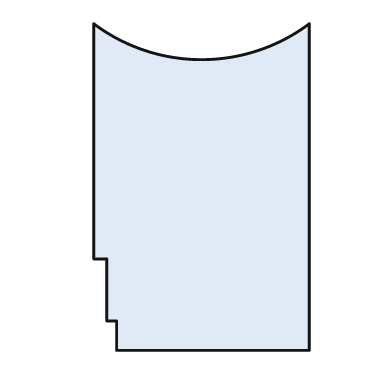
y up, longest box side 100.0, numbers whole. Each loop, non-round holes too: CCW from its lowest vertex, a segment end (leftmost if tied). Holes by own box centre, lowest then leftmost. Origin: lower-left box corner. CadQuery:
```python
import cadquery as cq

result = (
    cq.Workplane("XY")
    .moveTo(7.0, 0.0)
    .lineTo(66.0, 0.0)
    .lineTo(66.0, 100.0)
    .threePointArc((33.0, 89.0), (0.0, 100.0))
    .lineTo(0.0, 28.0)
    .lineTo(4.0, 28.0)
    .lineTo(4.0, 9.0)
    .lineTo(7.0, 9.0)
    .close()
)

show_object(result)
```